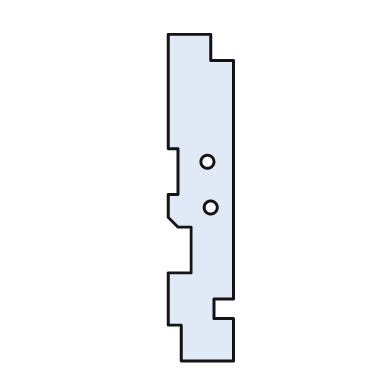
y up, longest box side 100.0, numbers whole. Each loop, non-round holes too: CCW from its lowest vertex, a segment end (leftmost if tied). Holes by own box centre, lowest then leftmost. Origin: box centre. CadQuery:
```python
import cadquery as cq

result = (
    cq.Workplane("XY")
    .moveTo(-6.0, -50.0)
    .lineTo(10.0, -50.0)
    .lineTo(10.0, -37.0)
    .lineTo(4.0, -37.0)
    .lineTo(4.0, -31.0)
    .lineTo(10.0, -31.0)
    .lineTo(10.0, 42.0)
    .lineTo(3.0, 42.0)
    .lineTo(3.0, 50.0)
    .lineTo(-10.0, 50.0)
    .lineTo(-10.0, 15.0)
    .lineTo(-7.0, 15.0)
    .lineTo(-7.0, 1.0)
    .lineTo(-10.0, 1.0)
    .lineTo(-10.0, -6.0)
    .lineTo(-7.0, -9.0)
    .lineTo(-3.0, -9.0)
    .lineTo(-3.0, -23.0)
    .lineTo(-10.0, -23.0)
    .lineTo(-10.0, -39.0)
    .lineTo(-6.0, -39.0)
    .close()
    .moveTo(3.0, -3.0)
    .circle(2.0)
    .moveTo(2.0, 11.0)
    .circle(2.0)
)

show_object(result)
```